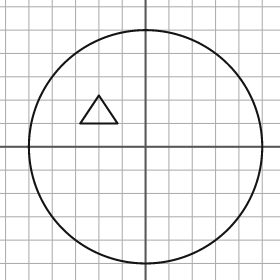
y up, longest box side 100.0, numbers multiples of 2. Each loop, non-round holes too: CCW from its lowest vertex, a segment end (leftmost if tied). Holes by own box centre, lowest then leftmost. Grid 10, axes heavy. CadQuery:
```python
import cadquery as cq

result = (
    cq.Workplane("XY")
    .moveTo(0.0, 0.0)
    .circle(50.0)
    .moveTo(-28.0, 10.0)
    .lineTo(-12.0, 10.0)
    .lineTo(-20.0, 22.0)
    .close()
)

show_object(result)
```